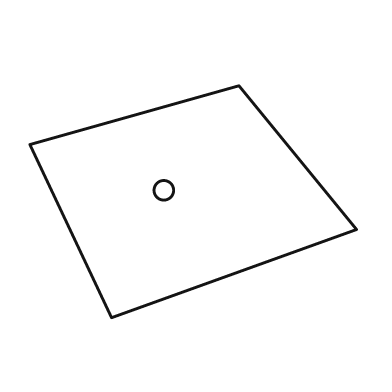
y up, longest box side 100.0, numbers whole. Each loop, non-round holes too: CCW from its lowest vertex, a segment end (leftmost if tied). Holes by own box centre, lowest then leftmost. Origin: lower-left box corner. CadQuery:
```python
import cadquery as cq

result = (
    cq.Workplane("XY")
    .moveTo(25.0, 0.0)
    .lineTo(100.0, 27.0)
    .lineTo(64.0, 71.0)
    .lineTo(0.0, 53.0)
    .close()
    .moveTo(41.0, 39.0)
    .circle(3.0)
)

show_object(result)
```